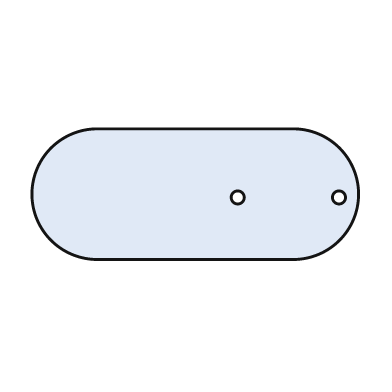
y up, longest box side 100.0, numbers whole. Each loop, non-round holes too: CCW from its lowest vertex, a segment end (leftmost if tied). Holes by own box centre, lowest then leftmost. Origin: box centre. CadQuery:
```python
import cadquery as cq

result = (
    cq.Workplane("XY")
    .moveTo(-30.0, -20.0)
    .lineTo(30.0, -20.0)
    .threePointArc((50.0, 0.0), (30.0, 20.0))
    .lineTo(-30.0, 20.0)
    .threePointArc((-50.0, 0.0), (-30.0, -20.0))
    .close()
    .moveTo(13.0, -1.0)
    .circle(2.0)
    .moveTo(44.0, -1.0)
    .circle(2.0)
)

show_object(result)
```